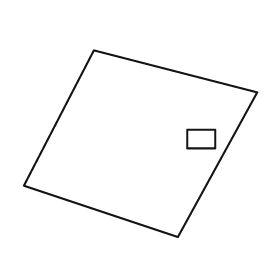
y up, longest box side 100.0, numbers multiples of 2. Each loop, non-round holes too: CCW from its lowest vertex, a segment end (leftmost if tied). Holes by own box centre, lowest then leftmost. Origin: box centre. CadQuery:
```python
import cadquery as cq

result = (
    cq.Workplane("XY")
    .moveTo(16.0, -40.0)
    .lineTo(50.0, 22.0)
    .lineTo(-20.0, 40.0)
    .lineTo(-50.0, -18.0)
    .close()
    .moveTo(20.0, -2.0)
    .lineTo(32.0, -2.0)
    .lineTo(32.0, 6.0)
    .lineTo(20.0, 6.0)
    .close()
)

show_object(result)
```